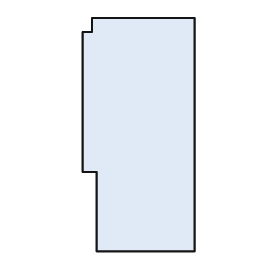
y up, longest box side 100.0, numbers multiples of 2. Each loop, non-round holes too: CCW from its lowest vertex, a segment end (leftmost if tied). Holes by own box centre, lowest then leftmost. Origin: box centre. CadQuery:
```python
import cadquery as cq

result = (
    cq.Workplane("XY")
    .moveTo(-18.0, -50.0)
    .lineTo(24.0, -50.0)
    .lineTo(24.0, 50.0)
    .lineTo(-20.0, 50.0)
    .lineTo(-20.0, 44.0)
    .lineTo(-24.0, 44.0)
    .lineTo(-24.0, -16.0)
    .lineTo(-18.0, -16.0)
    .close()
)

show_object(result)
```